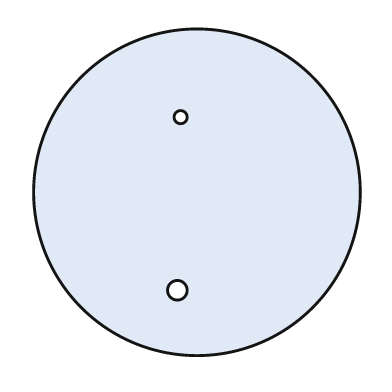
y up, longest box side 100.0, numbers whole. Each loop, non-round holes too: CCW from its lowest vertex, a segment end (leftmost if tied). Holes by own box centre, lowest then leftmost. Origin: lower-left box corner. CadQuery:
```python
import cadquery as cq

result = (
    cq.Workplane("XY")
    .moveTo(50.0, 50.0)
    .circle(50.0)
    .moveTo(44.0, 20.0)
    .circle(3.0)
    .moveTo(45.0, 73.0)
    .circle(2.0)
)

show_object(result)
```